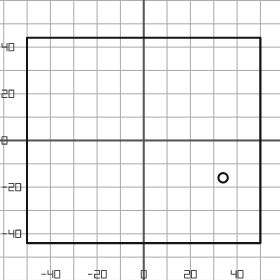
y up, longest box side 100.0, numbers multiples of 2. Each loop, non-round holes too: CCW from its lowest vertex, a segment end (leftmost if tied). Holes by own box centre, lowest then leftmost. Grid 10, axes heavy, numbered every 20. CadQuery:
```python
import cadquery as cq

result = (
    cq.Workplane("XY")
    .moveTo(-50.0, -44.0)
    .lineTo(50.0, -44.0)
    .lineTo(50.0, 44.0)
    .lineTo(-50.0, 44.0)
    .close()
    .moveTo(34.0, -16.0)
    .circle(2.0)
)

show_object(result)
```